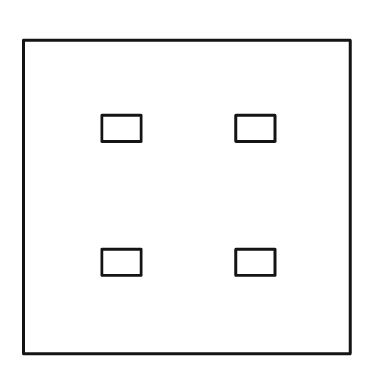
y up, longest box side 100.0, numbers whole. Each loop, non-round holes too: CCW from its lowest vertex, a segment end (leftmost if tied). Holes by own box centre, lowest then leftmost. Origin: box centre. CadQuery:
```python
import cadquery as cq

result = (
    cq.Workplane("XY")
    .moveTo(-50.0, -48.0)
    .lineTo(50.0, -48.0)
    .lineTo(50.0, 48.0)
    .lineTo(-50.0, 48.0)
    .close()
    .moveTo(-26.0, -24.0)
    .lineTo(-14.0, -24.0)
    .lineTo(-14.0, -16.0)
    .lineTo(-26.0, -16.0)
    .close()
    .moveTo(15.0, -24.0)
    .lineTo(27.0, -24.0)
    .lineTo(27.0, -16.0)
    .lineTo(15.0, -16.0)
    .close()
    .moveTo(-26.0, 17.0)
    .lineTo(-14.0, 17.0)
    .lineTo(-14.0, 25.0)
    .lineTo(-26.0, 25.0)
    .close()
    .moveTo(15.0, 17.0)
    .lineTo(27.0, 17.0)
    .lineTo(27.0, 25.0)
    .lineTo(15.0, 25.0)
    .close()
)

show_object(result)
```